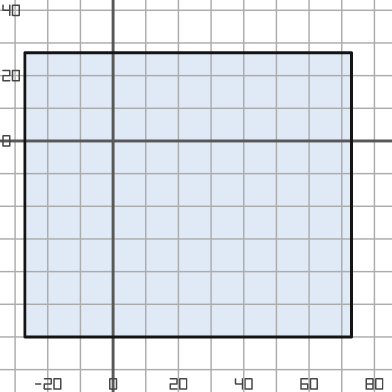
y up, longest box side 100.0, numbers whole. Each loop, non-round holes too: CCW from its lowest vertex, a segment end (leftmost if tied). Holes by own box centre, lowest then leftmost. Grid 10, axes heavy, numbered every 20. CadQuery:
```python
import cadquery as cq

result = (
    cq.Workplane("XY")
    .moveTo(-27.0, -60.0)
    .lineTo(73.0, -60.0)
    .lineTo(73.0, 27.0)
    .lineTo(-27.0, 27.0)
    .close()
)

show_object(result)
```